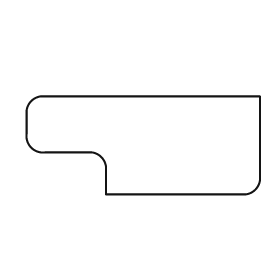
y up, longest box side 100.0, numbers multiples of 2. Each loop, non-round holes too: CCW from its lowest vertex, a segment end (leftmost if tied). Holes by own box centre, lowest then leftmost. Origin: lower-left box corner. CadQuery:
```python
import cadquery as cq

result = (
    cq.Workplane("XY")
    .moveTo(34.0, 0.0)
    .lineTo(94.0, 0.0)
    .threePointArc((98.0, 2.0), (100.0, 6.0))
    .lineTo(100.0, 42.0)
    .lineTo(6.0, 42.0)
    .threePointArc((2.0, 40.0), (0.0, 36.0))
    .lineTo(0.0, 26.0)
    .threePointArc((2.0, 20.0), (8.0, 18.0))
    .lineTo(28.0, 18.0)
    .threePointArc((32.0, 16.0), (34.0, 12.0))
    .close()
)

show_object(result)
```